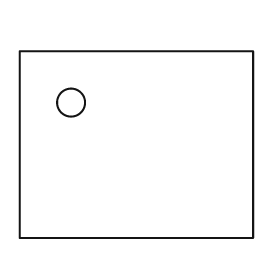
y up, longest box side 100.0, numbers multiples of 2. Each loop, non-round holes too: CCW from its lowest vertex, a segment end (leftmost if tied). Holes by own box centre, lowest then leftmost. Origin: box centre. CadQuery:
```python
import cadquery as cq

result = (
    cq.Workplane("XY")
    .moveTo(-50.0, -40.0)
    .lineTo(50.0, -40.0)
    .lineTo(50.0, 40.0)
    .lineTo(-50.0, 40.0)
    .close()
    .moveTo(-28.0, 18.0)
    .circle(6.0)
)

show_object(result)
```